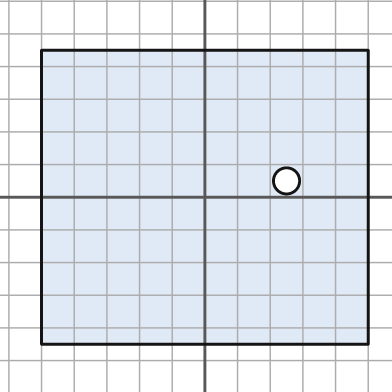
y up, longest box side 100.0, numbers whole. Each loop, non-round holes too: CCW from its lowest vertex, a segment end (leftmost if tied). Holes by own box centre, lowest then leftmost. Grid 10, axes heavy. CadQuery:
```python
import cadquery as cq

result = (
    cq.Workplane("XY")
    .moveTo(-50.0, -45.0)
    .lineTo(50.0, -45.0)
    .lineTo(50.0, 45.0)
    .lineTo(-50.0, 45.0)
    .close()
    .moveTo(25.0, 5.0)
    .circle(4.0)
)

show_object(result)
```